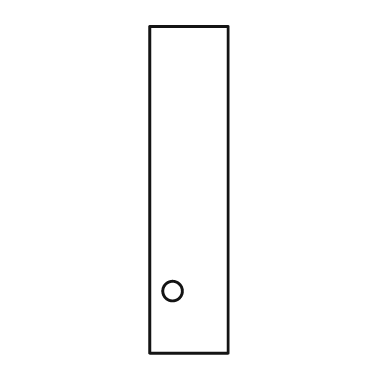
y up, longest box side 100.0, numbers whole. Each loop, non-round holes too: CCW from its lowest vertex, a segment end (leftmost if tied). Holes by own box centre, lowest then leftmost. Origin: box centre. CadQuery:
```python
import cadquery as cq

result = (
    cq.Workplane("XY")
    .moveTo(-12.0, -50.0)
    .lineTo(12.0, -50.0)
    .lineTo(12.0, 50.0)
    .lineTo(-12.0, 50.0)
    .close()
    .moveTo(-5.0, -31.0)
    .circle(3.0)
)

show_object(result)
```